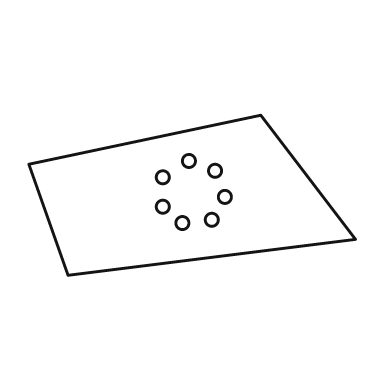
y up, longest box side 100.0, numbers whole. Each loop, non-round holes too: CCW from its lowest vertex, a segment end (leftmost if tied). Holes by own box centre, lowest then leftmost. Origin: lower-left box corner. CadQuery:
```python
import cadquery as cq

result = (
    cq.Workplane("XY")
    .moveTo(12.0, 0.0)
    .lineTo(100.0, 11.0)
    .lineTo(71.0, 49.0)
    .lineTo(0.0, 34.0)
    .close()
    .moveTo(47.0, 16.0)
    .circle(2.0)
    .moveTo(56.0, 17.0)
    .circle(2.0)
    .moveTo(41.0, 21.0)
    .circle(2.0)
    .moveTo(60.0, 24.0)
    .circle(2.0)
    .moveTo(41.0, 30.0)
    .circle(2.0)
    .moveTo(57.0, 32.0)
    .circle(2.0)
    .moveTo(49.0, 35.0)
    .circle(2.0)
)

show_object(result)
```